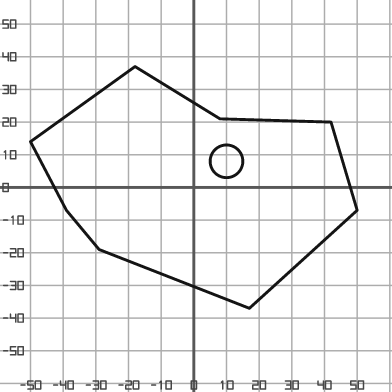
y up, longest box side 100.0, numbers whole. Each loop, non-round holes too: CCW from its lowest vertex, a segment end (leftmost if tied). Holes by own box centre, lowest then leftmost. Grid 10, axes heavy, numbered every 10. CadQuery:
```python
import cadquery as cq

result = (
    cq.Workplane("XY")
    .moveTo(17.0, -37.0)
    .lineTo(50.0, -7.0)
    .lineTo(42.0, 20.0)
    .lineTo(8.0, 21.0)
    .lineTo(-18.0, 37.0)
    .lineTo(-50.0, 14.0)
    .lineTo(-39.0, -7.0)
    .lineTo(-29.0, -19.0)
    .close()
    .moveTo(10.0, 8.0)
    .circle(5.0)
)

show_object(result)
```